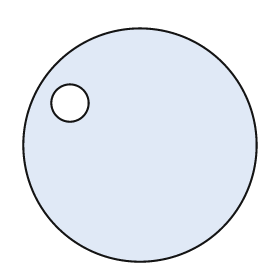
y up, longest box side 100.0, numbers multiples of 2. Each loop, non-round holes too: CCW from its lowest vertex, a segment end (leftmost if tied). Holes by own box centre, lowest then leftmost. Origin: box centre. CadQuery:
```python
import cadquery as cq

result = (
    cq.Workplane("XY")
    .moveTo(0.0, 0.0)
    .circle(50.0)
    .moveTo(-30.0, 18.0)
    .circle(8.0)
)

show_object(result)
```